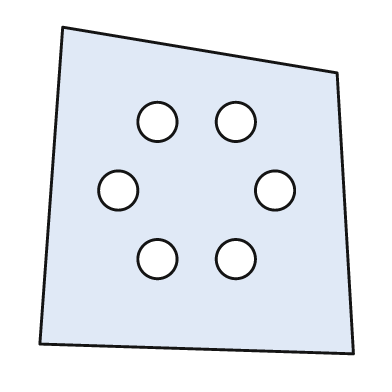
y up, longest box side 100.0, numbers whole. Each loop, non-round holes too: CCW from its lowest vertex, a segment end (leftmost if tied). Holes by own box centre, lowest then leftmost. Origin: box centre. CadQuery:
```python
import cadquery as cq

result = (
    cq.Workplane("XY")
    .moveTo(48.0, -50.0)
    .lineTo(43.0, 36.0)
    .lineTo(-41.0, 50.0)
    .lineTo(-48.0, -47.0)
    .close()
    .moveTo(-12.0, -21.0)
    .circle(6.0)
    .moveTo(12.0, -21.0)
    .circle(6.0)
    .moveTo(-24.0, 0.0)
    .circle(6.0)
    .moveTo(24.0, 0.0)
    .circle(6.0)
    .moveTo(-12.0, 21.0)
    .circle(6.0)
    .moveTo(12.0, 21.0)
    .circle(6.0)
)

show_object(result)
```